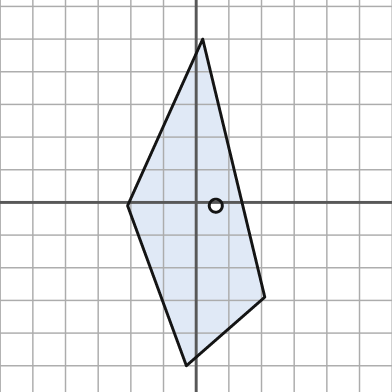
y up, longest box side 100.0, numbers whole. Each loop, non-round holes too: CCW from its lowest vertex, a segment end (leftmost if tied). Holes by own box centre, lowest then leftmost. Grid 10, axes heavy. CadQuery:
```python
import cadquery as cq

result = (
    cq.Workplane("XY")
    .moveTo(-3.0, -50.0)
    .lineTo(21.0, -29.0)
    .lineTo(2.0, 50.0)
    .lineTo(-21.0, -1.0)
    .close()
    .moveTo(6.0, -1.0)
    .circle(2.0)
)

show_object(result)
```